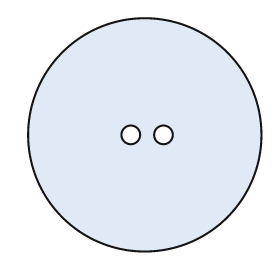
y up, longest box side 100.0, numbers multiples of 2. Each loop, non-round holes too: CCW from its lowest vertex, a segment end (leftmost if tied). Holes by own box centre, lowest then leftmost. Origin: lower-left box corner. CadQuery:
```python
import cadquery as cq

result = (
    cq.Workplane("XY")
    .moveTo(50.0, 50.0)
    .circle(50.0)
    .moveTo(44.0, 50.0)
    .circle(4.0)
    .moveTo(58.0, 50.0)
    .circle(4.0)
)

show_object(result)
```